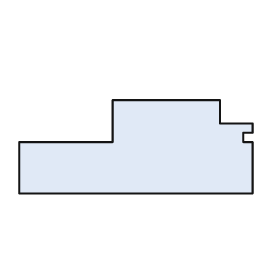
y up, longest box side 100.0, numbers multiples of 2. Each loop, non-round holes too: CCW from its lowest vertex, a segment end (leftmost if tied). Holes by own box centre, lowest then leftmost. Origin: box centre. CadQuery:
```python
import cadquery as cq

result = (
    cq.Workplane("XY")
    .moveTo(-50.0, -20.0)
    .lineTo(50.0, -20.0)
    .lineTo(50.0, 2.0)
    .lineTo(46.0, 2.0)
    .lineTo(46.0, 6.0)
    .lineTo(50.0, 6.0)
    .lineTo(50.0, 10.0)
    .lineTo(36.0, 10.0)
    .lineTo(36.0, 20.0)
    .lineTo(-10.0, 20.0)
    .lineTo(-10.0, 2.0)
    .lineTo(-50.0, 2.0)
    .close()
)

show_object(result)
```